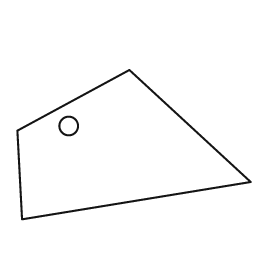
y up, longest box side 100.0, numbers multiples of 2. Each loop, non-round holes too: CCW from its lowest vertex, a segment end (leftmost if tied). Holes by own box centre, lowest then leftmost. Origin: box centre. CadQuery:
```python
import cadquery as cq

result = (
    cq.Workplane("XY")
    .moveTo(-48.0, -32.0)
    .lineTo(50.0, -16.0)
    .lineTo(-2.0, 32.0)
    .lineTo(-50.0, 6.0)
    .close()
    .moveTo(-28.0, 8.0)
    .circle(4.0)
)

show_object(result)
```